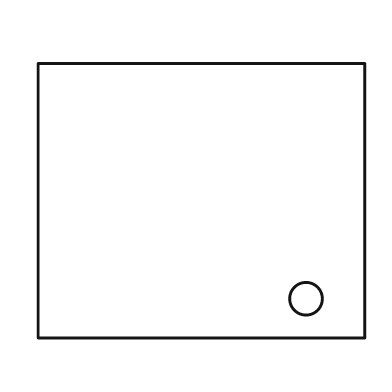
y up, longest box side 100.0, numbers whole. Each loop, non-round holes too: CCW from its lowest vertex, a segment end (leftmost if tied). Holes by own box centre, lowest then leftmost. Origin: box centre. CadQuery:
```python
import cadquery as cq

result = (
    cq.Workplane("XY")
    .moveTo(-50.0, -42.0)
    .lineTo(50.0, -42.0)
    .lineTo(50.0, 42.0)
    .lineTo(-50.0, 42.0)
    .close()
    .moveTo(32.0, -30.0)
    .circle(5.0)
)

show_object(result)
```